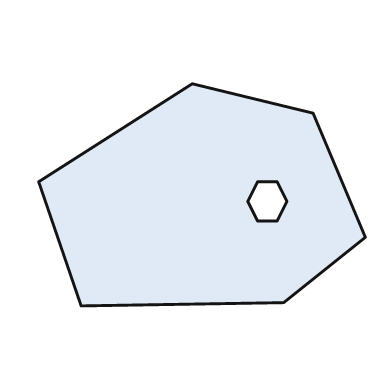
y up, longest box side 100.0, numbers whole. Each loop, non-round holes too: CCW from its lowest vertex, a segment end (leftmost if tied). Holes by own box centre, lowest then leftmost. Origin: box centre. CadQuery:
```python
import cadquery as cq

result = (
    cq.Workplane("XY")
    .moveTo(-37.0, -34.0)
    .lineTo(25.0, -33.0)
    .lineTo(50.0, -13.0)
    .lineTo(34.0, 25.0)
    .lineTo(-3.0, 34.0)
    .lineTo(-50.0, 4.0)
    .close()
    .moveTo(17.0, -8.0)
    .lineTo(23.0, -8.0)
    .lineTo(26.0, -2.0)
    .lineTo(23.0, 4.0)
    .lineTo(17.0, 4.0)
    .lineTo(14.0, -2.0)
    .close()
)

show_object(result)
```